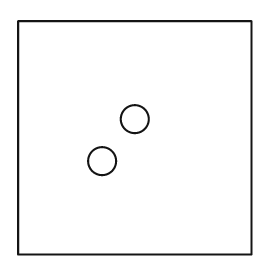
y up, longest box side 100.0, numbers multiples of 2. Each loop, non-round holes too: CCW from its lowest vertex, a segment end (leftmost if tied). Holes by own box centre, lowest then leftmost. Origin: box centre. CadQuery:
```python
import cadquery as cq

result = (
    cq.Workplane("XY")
    .moveTo(-50.0, -50.0)
    .lineTo(50.0, -50.0)
    .lineTo(50.0, 50.0)
    .lineTo(-50.0, 50.0)
    .close()
    .moveTo(-14.0, -10.0)
    .circle(6.0)
    .moveTo(0.0, 8.0)
    .circle(6.0)
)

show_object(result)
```